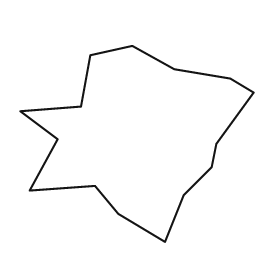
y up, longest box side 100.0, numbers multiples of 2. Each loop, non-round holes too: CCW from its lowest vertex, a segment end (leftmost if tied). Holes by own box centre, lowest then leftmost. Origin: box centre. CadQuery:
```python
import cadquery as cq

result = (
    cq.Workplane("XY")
    .moveTo(12.0, -42.0)
    .lineTo(20.0, -22.0)
    .lineTo(32.0, -10.0)
    .lineTo(34.0, 0.0)
    .lineTo(50.0, 22.0)
    .lineTo(40.0, 28.0)
    .lineTo(16.0, 32.0)
    .lineTo(-2.0, 42.0)
    .lineTo(-20.0, 38.0)
    .lineTo(-24.0, 16.0)
    .lineTo(-50.0, 14.0)
    .lineTo(-34.0, 2.0)
    .lineTo(-46.0, -20.0)
    .lineTo(-18.0, -18.0)
    .lineTo(-8.0, -30.0)
    .close()
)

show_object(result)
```